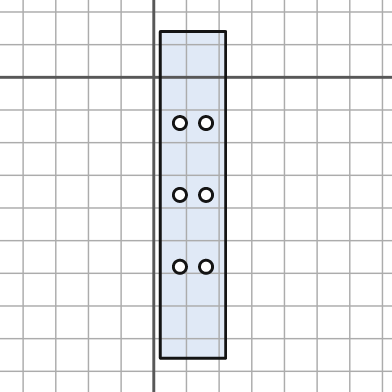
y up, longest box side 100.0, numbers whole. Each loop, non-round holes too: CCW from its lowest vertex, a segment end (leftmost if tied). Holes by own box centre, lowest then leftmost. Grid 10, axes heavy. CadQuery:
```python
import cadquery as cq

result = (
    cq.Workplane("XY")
    .moveTo(2.0, -86.0)
    .lineTo(22.0, -86.0)
    .lineTo(22.0, 14.0)
    .lineTo(2.0, 14.0)
    .close()
    .moveTo(8.0, -58.0)
    .circle(2.0)
    .moveTo(16.0, -58.0)
    .circle(2.0)
    .moveTo(8.0, -36.0)
    .circle(2.0)
    .moveTo(16.0, -36.0)
    .circle(2.0)
    .moveTo(8.0, -14.0)
    .circle(2.0)
    .moveTo(16.0, -14.0)
    .circle(2.0)
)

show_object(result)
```